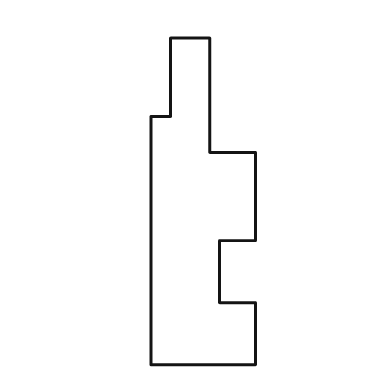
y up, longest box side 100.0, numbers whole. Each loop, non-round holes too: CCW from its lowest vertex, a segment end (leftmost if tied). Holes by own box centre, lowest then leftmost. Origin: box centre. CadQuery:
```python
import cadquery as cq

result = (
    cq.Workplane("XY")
    .moveTo(-16.0, -50.0)
    .lineTo(16.0, -50.0)
    .lineTo(16.0, -31.0)
    .lineTo(5.0, -31.0)
    .lineTo(5.0, -12.0)
    .lineTo(16.0, -12.0)
    .lineTo(16.0, 15.0)
    .lineTo(2.0, 15.0)
    .lineTo(2.0, 50.0)
    .lineTo(-10.0, 50.0)
    .lineTo(-10.0, 26.0)
    .lineTo(-16.0, 26.0)
    .close()
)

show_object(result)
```